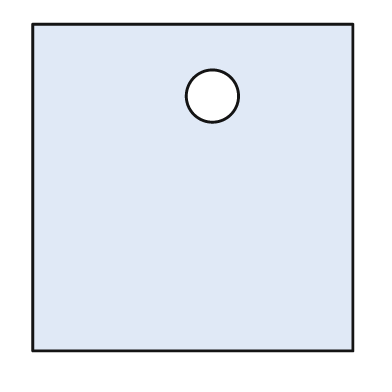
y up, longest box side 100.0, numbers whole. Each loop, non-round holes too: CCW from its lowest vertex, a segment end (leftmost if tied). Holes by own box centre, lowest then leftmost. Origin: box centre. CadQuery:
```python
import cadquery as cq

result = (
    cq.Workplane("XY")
    .moveTo(-49.0, -50.0)
    .lineTo(49.0, -50.0)
    .lineTo(49.0, 50.0)
    .lineTo(-49.0, 50.0)
    .close()
    .moveTo(6.0, 28.0)
    .circle(8.0)
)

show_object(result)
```